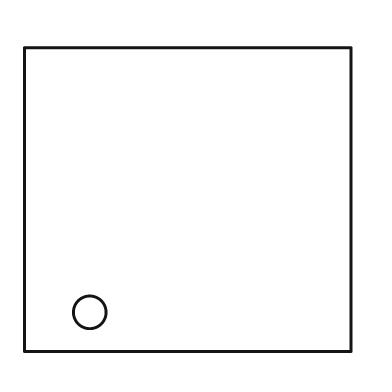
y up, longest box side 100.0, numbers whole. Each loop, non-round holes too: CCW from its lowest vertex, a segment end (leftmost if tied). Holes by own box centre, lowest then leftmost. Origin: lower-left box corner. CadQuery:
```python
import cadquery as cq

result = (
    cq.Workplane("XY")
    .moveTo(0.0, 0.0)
    .lineTo(100.0, 0.0)
    .lineTo(100.0, 93.0)
    .lineTo(0.0, 93.0)
    .close()
    .moveTo(20.0, 12.0)
    .circle(5.0)
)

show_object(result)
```